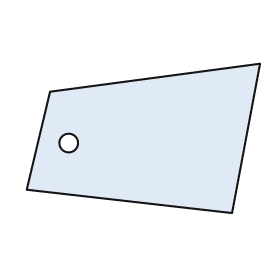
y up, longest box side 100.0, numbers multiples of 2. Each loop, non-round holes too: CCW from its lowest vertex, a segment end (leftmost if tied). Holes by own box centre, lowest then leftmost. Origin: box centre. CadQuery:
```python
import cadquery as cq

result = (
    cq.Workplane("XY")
    .moveTo(38.0, -32.0)
    .lineTo(50.0, 32.0)
    .lineTo(-40.0, 20.0)
    .lineTo(-50.0, -22.0)
    .close()
    .moveTo(-32.0, -2.0)
    .circle(4.0)
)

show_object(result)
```